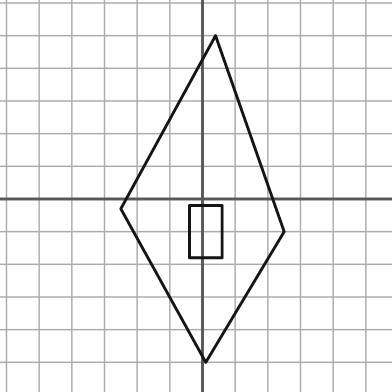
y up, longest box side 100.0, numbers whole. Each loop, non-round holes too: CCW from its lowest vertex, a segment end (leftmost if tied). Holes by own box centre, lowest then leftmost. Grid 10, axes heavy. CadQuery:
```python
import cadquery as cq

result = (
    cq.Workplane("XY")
    .moveTo(1.0, -50.0)
    .lineTo(25.0, -10.0)
    .lineTo(4.0, 50.0)
    .lineTo(-25.0, -3.0)
    .close()
    .moveTo(-4.0, -18.0)
    .lineTo(6.0, -18.0)
    .lineTo(6.0, -2.0)
    .lineTo(-4.0, -2.0)
    .close()
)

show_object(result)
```